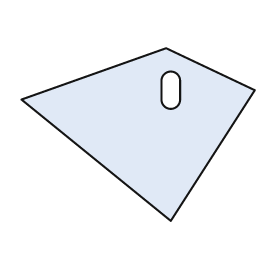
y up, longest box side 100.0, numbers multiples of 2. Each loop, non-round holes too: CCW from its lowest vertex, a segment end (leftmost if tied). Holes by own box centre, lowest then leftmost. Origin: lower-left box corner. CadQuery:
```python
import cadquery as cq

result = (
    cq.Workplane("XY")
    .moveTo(64.0, 0.0)
    .lineTo(100.0, 56.0)
    .lineTo(62.0, 74.0)
    .lineTo(0.0, 52.0)
    .close()
    .moveTo(60.0, 52.0)
    .threePointArc((64.0, 48.0), (68.0, 52.0))
    .lineTo(68.0, 60.0)
    .threePointArc((64.0, 64.0), (60.0, 60.0))
    .close()
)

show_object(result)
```